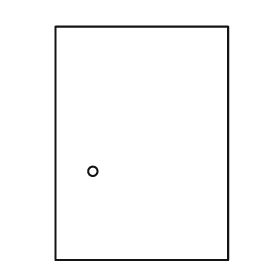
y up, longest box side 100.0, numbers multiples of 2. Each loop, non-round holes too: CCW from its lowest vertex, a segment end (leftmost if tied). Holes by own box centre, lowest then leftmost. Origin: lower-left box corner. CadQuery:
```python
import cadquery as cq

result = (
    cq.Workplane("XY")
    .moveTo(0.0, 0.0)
    .lineTo(74.0, 0.0)
    .lineTo(74.0, 100.0)
    .lineTo(0.0, 100.0)
    .close()
    .moveTo(16.0, 38.0)
    .circle(2.0)
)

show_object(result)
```